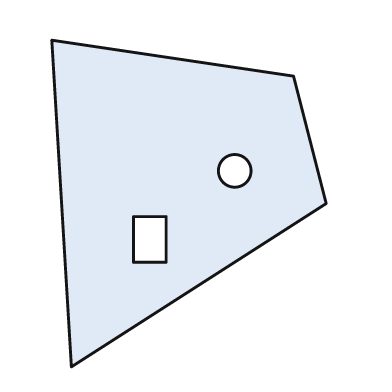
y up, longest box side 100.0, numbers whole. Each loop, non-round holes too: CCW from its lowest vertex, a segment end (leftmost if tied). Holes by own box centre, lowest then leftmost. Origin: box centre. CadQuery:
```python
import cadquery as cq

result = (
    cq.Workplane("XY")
    .moveTo(-36.0, -50.0)
    .lineTo(42.0, 0.0)
    .lineTo(32.0, 39.0)
    .lineTo(-42.0, 50.0)
    .close()
    .moveTo(-17.0, -18.0)
    .lineTo(-7.0, -18.0)
    .lineTo(-7.0, -4.0)
    .lineTo(-17.0, -4.0)
    .close()
    .moveTo(14.0, 10.0)
    .circle(5.0)
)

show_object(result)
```